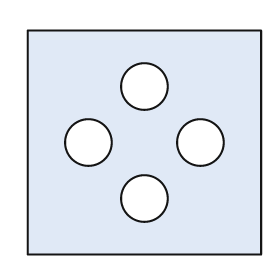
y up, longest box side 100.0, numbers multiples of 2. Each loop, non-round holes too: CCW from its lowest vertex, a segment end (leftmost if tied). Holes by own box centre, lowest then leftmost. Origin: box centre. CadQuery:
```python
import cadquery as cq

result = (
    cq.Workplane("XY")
    .moveTo(-50.0, -48.0)
    .lineTo(50.0, -48.0)
    .lineTo(50.0, 48.0)
    .lineTo(-50.0, 48.0)
    .close()
    .moveTo(0.0, -24.0)
    .circle(10.0)
    .moveTo(-24.0, 0.0)
    .circle(10.0)
    .moveTo(24.0, 0.0)
    .circle(10.0)
    .moveTo(0.0, 24.0)
    .circle(10.0)
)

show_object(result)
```